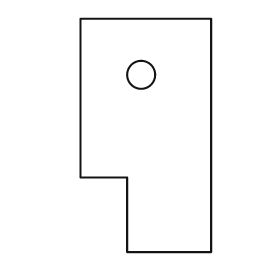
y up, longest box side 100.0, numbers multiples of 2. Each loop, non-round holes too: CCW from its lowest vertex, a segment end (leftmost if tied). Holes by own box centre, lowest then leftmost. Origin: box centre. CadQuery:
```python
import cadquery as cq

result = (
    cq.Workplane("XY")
    .moveTo(-8.0, -50.0)
    .lineTo(28.0, -50.0)
    .lineTo(28.0, 50.0)
    .lineTo(-28.0, 50.0)
    .lineTo(-28.0, -18.0)
    .lineTo(-8.0, -18.0)
    .close()
    .moveTo(-2.0, 26.0)
    .circle(6.0)
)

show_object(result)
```